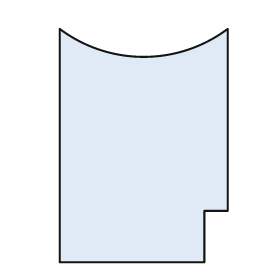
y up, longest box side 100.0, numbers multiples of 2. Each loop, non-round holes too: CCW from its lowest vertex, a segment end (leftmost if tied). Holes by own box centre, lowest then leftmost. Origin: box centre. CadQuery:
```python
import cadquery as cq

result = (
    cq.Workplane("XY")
    .moveTo(-36.0, -50.0)
    .lineTo(26.0, -50.0)
    .lineTo(26.0, -28.0)
    .lineTo(36.0, -28.0)
    .lineTo(36.0, 50.0)
    .threePointArc((0.0, 38.0), (-36.0, 50.0))
    .close()
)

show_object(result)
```